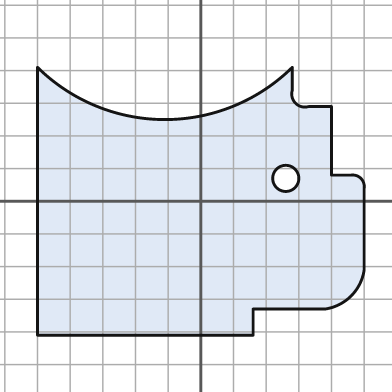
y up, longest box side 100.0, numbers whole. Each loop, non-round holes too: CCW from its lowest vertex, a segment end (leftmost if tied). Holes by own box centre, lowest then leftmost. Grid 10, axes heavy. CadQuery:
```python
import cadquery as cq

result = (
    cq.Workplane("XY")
    .moveTo(-50.0, -41.0)
    .lineTo(16.0, -41.0)
    .lineTo(16.0, -33.0)
    .lineTo(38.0, -33.0)
    .threePointArc((46.0, -29.0), (50.0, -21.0))
    .lineTo(50.0, 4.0)
    .threePointArc((49.0, 7.0), (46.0, 8.0))
    .lineTo(40.0, 8.0)
    .lineTo(40.0, 29.0)
    .lineTo(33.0, 29.0)
    .threePointArc((29.0, 30.0), (28.0, 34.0))
    .lineTo(28.0, 41.0)
    .threePointArc((-11.0, 25.0), (-50.0, 41.0))
    .close()
    .moveTo(26.0, 7.0)
    .circle(4.0)
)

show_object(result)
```